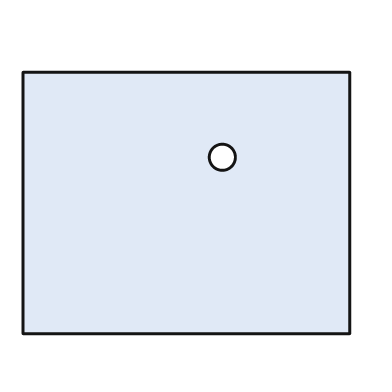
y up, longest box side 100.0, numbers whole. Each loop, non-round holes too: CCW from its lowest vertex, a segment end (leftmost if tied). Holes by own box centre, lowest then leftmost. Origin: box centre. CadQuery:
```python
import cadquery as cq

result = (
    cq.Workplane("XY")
    .moveTo(-50.0, -40.0)
    .lineTo(50.0, -40.0)
    .lineTo(50.0, 40.0)
    .lineTo(-50.0, 40.0)
    .close()
    .moveTo(11.0, 14.0)
    .circle(4.0)
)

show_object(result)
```